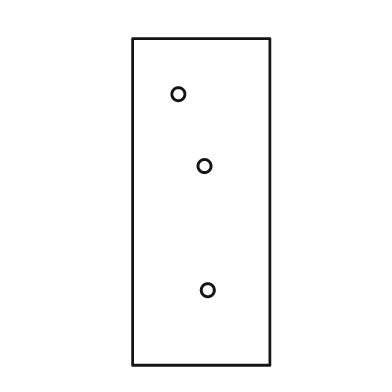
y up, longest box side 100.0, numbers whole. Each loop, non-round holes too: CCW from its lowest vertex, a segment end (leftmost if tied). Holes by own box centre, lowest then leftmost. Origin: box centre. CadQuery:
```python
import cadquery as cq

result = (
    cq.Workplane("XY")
    .moveTo(-21.0, -50.0)
    .lineTo(21.0, -50.0)
    .lineTo(21.0, 50.0)
    .lineTo(-21.0, 50.0)
    .close()
    .moveTo(2.0, -27.0)
    .circle(2.0)
    .moveTo(1.0, 11.0)
    .circle(2.0)
    .moveTo(-7.0, 33.0)
    .circle(2.0)
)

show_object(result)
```